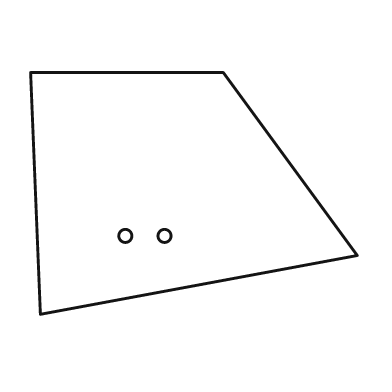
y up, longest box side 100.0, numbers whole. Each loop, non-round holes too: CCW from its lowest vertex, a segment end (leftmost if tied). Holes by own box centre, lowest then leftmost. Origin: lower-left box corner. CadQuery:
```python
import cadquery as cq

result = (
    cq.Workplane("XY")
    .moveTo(3.0, 0.0)
    .lineTo(100.0, 18.0)
    .lineTo(59.0, 74.0)
    .lineTo(0.0, 74.0)
    .close()
    .moveTo(29.0, 24.0)
    .circle(2.0)
    .moveTo(41.0, 24.0)
    .circle(2.0)
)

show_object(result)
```